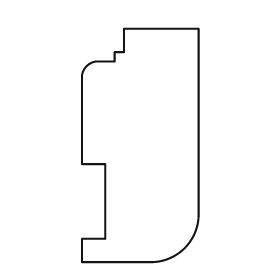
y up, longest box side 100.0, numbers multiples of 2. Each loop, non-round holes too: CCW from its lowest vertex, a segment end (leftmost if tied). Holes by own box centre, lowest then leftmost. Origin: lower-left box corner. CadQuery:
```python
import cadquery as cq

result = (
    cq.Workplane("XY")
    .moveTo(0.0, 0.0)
    .lineTo(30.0, 0.0)
    .threePointArc((44.0, 6.0), (50.0, 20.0))
    .lineTo(50.0, 100.0)
    .lineTo(18.0, 100.0)
    .lineTo(18.0, 90.0)
    .lineTo(14.0, 90.0)
    .lineTo(14.0, 86.0)
    .lineTo(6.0, 86.0)
    .threePointArc((2.0, 84.0), (0.0, 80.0))
    .lineTo(0.0, 42.0)
    .lineTo(10.0, 42.0)
    .lineTo(10.0, 10.0)
    .lineTo(0.0, 10.0)
    .close()
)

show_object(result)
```